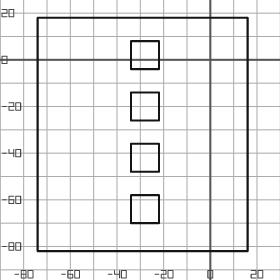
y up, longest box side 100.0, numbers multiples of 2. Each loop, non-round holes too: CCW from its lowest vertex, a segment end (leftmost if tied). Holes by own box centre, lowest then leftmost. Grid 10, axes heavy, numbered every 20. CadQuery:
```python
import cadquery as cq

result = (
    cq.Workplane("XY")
    .moveTo(-74.0, -82.0)
    .lineTo(16.0, -82.0)
    .lineTo(16.0, 18.0)
    .lineTo(-74.0, 18.0)
    .close()
    .moveTo(-34.0, -70.0)
    .lineTo(-22.0, -70.0)
    .lineTo(-22.0, -58.0)
    .lineTo(-34.0, -58.0)
    .close()
    .moveTo(-34.0, -48.0)
    .lineTo(-22.0, -48.0)
    .lineTo(-22.0, -36.0)
    .lineTo(-34.0, -36.0)
    .close()
    .moveTo(-34.0, -26.0)
    .lineTo(-22.0, -26.0)
    .lineTo(-22.0, -14.0)
    .lineTo(-34.0, -14.0)
    .close()
    .moveTo(-34.0, -4.0)
    .lineTo(-22.0, -4.0)
    .lineTo(-22.0, 8.0)
    .lineTo(-34.0, 8.0)
    .close()
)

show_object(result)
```